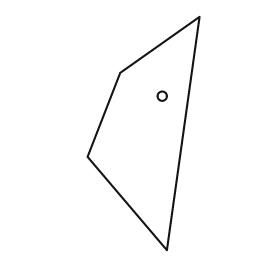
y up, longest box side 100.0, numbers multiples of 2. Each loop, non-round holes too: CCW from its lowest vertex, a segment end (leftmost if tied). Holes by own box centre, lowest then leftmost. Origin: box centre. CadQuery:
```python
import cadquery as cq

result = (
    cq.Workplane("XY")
    .moveTo(10.0, -50.0)
    .lineTo(24.0, 50.0)
    .lineTo(-10.0, 26.0)
    .lineTo(-24.0, -10.0)
    .close()
    .moveTo(8.0, 16.0)
    .circle(2.0)
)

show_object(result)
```